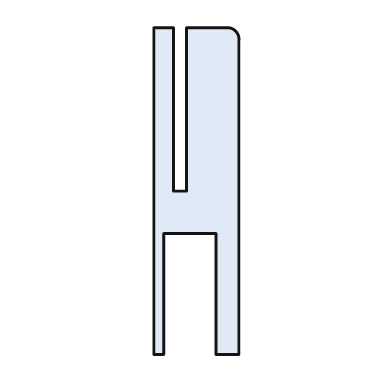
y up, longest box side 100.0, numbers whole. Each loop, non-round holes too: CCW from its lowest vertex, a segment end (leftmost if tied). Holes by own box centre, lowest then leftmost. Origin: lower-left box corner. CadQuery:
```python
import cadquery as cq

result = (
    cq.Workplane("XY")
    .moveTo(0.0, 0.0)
    .lineTo(3.0, 0.0)
    .lineTo(3.0, 37.0)
    .lineTo(19.0, 37.0)
    .lineTo(19.0, 0.0)
    .lineTo(26.0, 0.0)
    .lineTo(26.0, 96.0)
    .threePointArc((25.0, 99.0), (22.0, 100.0))
    .lineTo(10.0, 100.0)
    .lineTo(10.0, 50.0)
    .lineTo(6.0, 50.0)
    .lineTo(6.0, 100.0)
    .lineTo(0.0, 100.0)
    .close()
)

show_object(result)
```